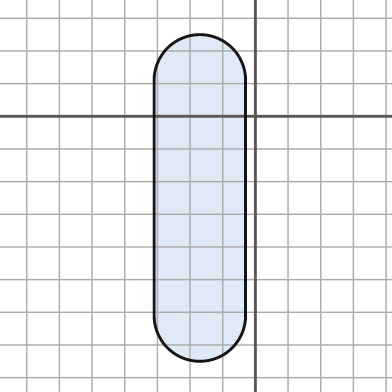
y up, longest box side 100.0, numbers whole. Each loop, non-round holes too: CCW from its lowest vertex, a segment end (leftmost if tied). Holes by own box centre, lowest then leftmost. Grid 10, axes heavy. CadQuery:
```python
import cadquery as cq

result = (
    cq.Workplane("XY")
    .moveTo(-31.0, -61.0)
    .threePointArc((-17.0, -75.0), (-3.0, -61.0))
    .lineTo(-3.0, 11.0)
    .threePointArc((-17.0, 25.0), (-31.0, 11.0))
    .close()
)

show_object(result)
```